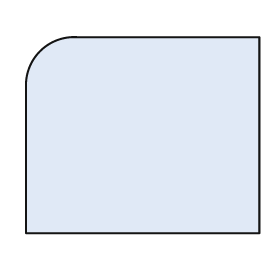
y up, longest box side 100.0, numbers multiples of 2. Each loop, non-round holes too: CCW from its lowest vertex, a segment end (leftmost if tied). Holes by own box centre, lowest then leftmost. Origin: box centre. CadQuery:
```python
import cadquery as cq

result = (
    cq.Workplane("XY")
    .moveTo(-50.0, -42.0)
    .lineTo(50.0, -42.0)
    .lineTo(50.0, 42.0)
    .lineTo(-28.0, 42.0)
    .threePointArc((-44.0, 36.0), (-50.0, 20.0))
    .close()
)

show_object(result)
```